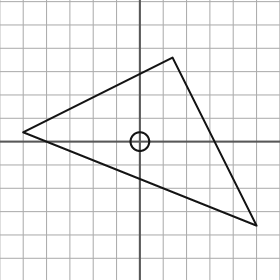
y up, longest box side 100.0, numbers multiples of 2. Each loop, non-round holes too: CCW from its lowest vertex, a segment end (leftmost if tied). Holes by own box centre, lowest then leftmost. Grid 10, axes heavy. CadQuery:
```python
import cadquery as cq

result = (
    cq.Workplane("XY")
    .moveTo(50.0, -36.0)
    .lineTo(14.0, 36.0)
    .lineTo(-50.0, 4.0)
    .close()
    .moveTo(0.0, 0.0)
    .circle(4.0)
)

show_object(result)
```